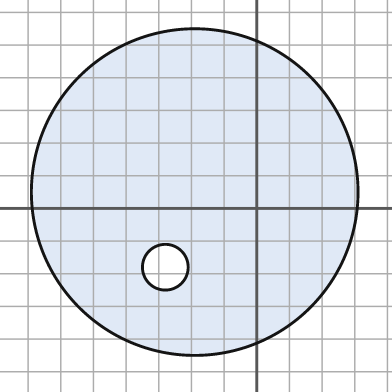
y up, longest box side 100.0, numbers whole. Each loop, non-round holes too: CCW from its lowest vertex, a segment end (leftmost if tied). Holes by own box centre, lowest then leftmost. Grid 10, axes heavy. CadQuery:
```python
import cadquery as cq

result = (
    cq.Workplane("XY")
    .moveTo(-19.0, 5.0)
    .circle(50.0)
    .moveTo(-28.0, -18.0)
    .circle(7.0)
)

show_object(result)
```